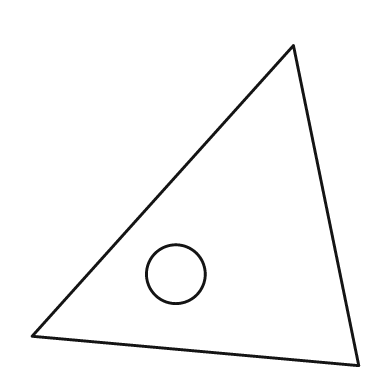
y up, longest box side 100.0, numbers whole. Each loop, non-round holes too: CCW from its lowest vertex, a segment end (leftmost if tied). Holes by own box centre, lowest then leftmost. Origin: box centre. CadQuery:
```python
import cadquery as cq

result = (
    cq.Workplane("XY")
    .moveTo(50.0, -49.0)
    .lineTo(30.0, 49.0)
    .lineTo(-50.0, -40.0)
    .close()
    .moveTo(-6.0, -21.0)
    .circle(9.0)
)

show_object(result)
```